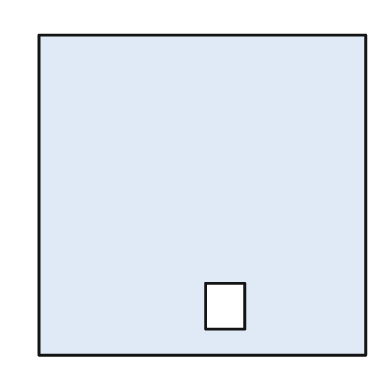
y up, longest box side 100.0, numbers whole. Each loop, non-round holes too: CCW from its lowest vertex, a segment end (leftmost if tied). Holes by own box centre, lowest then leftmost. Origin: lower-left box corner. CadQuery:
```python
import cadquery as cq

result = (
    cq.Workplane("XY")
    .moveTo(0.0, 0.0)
    .lineTo(100.0, 0.0)
    .lineTo(100.0, 98.0)
    .lineTo(0.0, 98.0)
    .close()
    .moveTo(51.0, 8.0)
    .lineTo(63.0, 8.0)
    .lineTo(63.0, 22.0)
    .lineTo(51.0, 22.0)
    .close()
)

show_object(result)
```